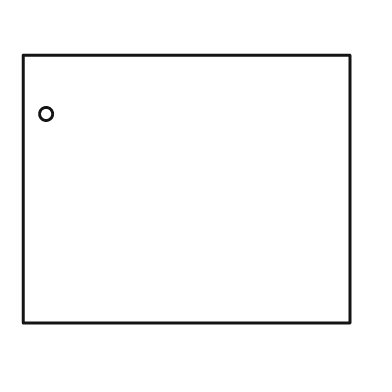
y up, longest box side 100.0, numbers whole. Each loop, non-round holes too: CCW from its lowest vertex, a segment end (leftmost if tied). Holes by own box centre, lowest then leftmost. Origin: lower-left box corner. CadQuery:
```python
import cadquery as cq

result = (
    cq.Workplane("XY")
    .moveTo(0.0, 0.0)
    .lineTo(100.0, 0.0)
    .lineTo(100.0, 82.0)
    .lineTo(0.0, 82.0)
    .close()
    .moveTo(7.0, 64.0)
    .circle(2.0)
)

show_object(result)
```